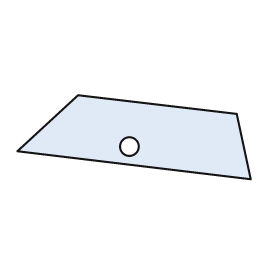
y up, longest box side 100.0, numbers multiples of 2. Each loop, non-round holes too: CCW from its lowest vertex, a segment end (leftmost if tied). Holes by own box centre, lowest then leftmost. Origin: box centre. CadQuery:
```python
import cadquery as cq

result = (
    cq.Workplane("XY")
    .moveTo(50.0, -18.0)
    .lineTo(44.0, 10.0)
    .lineTo(-24.0, 18.0)
    .lineTo(-50.0, -6.0)
    .close()
    .moveTo(-2.0, -4.0)
    .circle(4.0)
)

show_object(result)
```